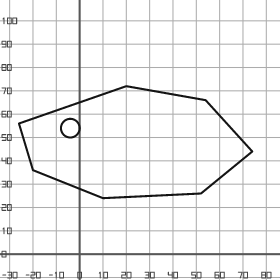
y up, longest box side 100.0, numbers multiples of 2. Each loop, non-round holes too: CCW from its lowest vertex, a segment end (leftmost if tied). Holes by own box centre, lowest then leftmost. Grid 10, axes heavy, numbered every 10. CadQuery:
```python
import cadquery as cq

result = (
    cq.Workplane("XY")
    .moveTo(10.0, 24.0)
    .lineTo(52.0, 26.0)
    .lineTo(74.0, 44.0)
    .lineTo(54.0, 66.0)
    .lineTo(20.0, 72.0)
    .lineTo(-26.0, 56.0)
    .lineTo(-20.0, 36.0)
    .close()
    .moveTo(-4.0, 54.0)
    .circle(4.0)
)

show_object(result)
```